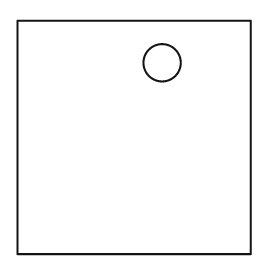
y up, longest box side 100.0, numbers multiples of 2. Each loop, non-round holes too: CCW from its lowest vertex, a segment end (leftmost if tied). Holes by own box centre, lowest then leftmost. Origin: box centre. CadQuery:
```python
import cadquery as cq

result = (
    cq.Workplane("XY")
    .moveTo(-50.0, -50.0)
    .lineTo(50.0, -50.0)
    .lineTo(50.0, 50.0)
    .lineTo(-50.0, 50.0)
    .close()
    .moveTo(12.0, 32.0)
    .circle(8.0)
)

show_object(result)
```